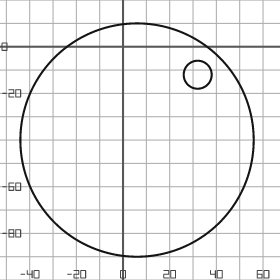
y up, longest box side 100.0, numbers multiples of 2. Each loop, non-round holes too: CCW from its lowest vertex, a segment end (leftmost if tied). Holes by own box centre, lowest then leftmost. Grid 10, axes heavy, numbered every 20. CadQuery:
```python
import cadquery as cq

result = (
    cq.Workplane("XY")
    .moveTo(6.0, -40.0)
    .circle(50.0)
    .moveTo(32.0, -12.0)
    .circle(6.0)
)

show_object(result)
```